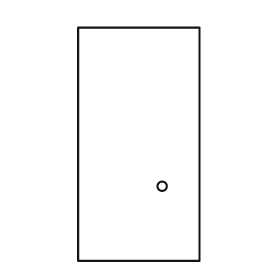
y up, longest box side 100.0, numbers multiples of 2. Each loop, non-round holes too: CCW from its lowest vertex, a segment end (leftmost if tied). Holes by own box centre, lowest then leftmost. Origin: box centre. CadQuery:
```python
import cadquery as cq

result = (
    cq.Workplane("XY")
    .moveTo(-26.0, -50.0)
    .lineTo(26.0, -50.0)
    .lineTo(26.0, 50.0)
    .lineTo(-26.0, 50.0)
    .close()
    .moveTo(10.0, -18.0)
    .circle(2.0)
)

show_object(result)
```